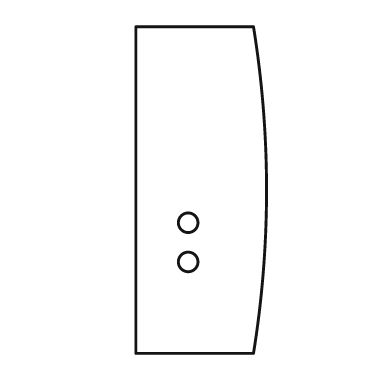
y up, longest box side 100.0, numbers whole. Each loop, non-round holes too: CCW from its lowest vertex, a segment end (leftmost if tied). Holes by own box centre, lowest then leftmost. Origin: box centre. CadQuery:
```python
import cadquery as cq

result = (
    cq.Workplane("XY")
    .moveTo(-20.0, -50.0)
    .lineTo(16.0, -50.0)
    .threePointArc((20.0, 0.0), (16.0, 50.0))
    .lineTo(-20.0, 50.0)
    .close()
    .moveTo(-4.0, -22.0)
    .circle(3.0)
    .moveTo(-4.0, -10.0)
    .circle(3.0)
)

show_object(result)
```